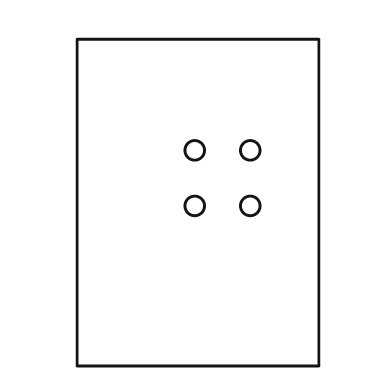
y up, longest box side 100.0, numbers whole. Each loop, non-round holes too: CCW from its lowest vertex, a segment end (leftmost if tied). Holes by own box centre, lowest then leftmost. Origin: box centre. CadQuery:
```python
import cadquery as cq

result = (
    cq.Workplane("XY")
    .moveTo(-37.0, -50.0)
    .lineTo(37.0, -50.0)
    .lineTo(37.0, 50.0)
    .lineTo(-37.0, 50.0)
    .close()
    .moveTo(-1.0, -1.0)
    .circle(3.0)
    .moveTo(16.0, -1.0)
    .circle(3.0)
    .moveTo(-1.0, 16.0)
    .circle(3.0)
    .moveTo(16.0, 16.0)
    .circle(3.0)
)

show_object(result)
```